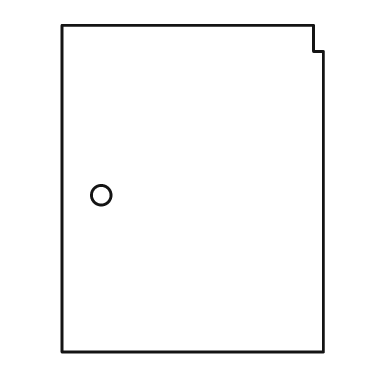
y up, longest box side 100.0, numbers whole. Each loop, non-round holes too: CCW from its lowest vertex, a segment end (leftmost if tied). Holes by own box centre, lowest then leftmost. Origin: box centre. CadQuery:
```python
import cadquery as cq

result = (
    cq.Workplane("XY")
    .moveTo(-40.0, -50.0)
    .lineTo(40.0, -50.0)
    .lineTo(40.0, 42.0)
    .lineTo(37.0, 42.0)
    .lineTo(37.0, 50.0)
    .lineTo(-40.0, 50.0)
    .close()
    .moveTo(-28.0, -2.0)
    .circle(3.0)
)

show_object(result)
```